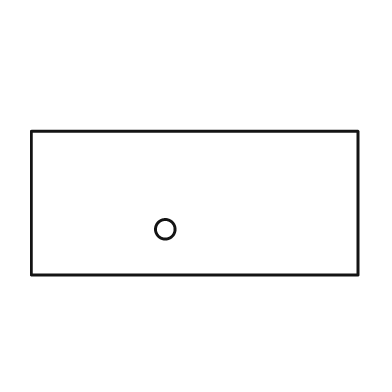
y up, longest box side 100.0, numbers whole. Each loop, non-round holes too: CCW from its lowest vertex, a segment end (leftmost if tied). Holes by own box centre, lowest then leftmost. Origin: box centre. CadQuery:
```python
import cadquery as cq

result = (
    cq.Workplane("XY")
    .moveTo(-50.0, -22.0)
    .lineTo(50.0, -22.0)
    .lineTo(50.0, 22.0)
    .lineTo(-50.0, 22.0)
    .close()
    .moveTo(-9.0, -8.0)
    .circle(3.0)
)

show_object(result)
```